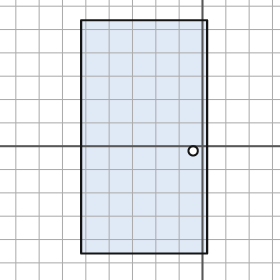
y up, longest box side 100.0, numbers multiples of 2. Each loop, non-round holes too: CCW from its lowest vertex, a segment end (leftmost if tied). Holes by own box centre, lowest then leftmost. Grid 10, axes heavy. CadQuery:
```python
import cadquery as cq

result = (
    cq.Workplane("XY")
    .moveTo(-52.0, -46.0)
    .lineTo(2.0, -46.0)
    .lineTo(2.0, 54.0)
    .lineTo(-52.0, 54.0)
    .close()
    .moveTo(-4.0, -2.0)
    .circle(2.0)
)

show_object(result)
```